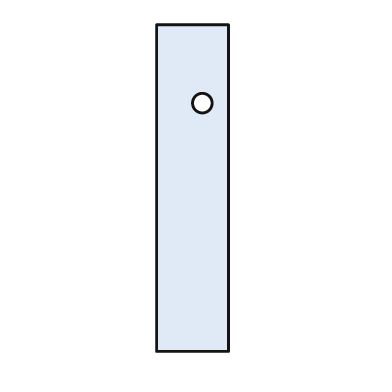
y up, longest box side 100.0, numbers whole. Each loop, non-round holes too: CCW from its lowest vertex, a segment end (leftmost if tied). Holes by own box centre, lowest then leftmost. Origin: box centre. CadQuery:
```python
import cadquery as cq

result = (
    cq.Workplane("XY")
    .moveTo(-11.0, -50.0)
    .lineTo(11.0, -50.0)
    .lineTo(11.0, 50.0)
    .lineTo(-11.0, 50.0)
    .close()
    .moveTo(3.0, 26.0)
    .circle(3.0)
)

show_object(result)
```